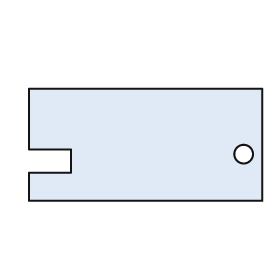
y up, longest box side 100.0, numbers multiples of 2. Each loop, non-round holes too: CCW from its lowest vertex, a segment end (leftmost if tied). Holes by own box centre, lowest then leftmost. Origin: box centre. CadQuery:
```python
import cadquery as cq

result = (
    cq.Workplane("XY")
    .moveTo(-50.0, -24.0)
    .lineTo(50.0, -24.0)
    .lineTo(50.0, 24.0)
    .lineTo(-50.0, 24.0)
    .lineTo(-50.0, -2.0)
    .lineTo(-32.0, -2.0)
    .lineTo(-32.0, -12.0)
    .lineTo(-50.0, -12.0)
    .close()
    .moveTo(42.0, -4.0)
    .circle(4.0)
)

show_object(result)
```